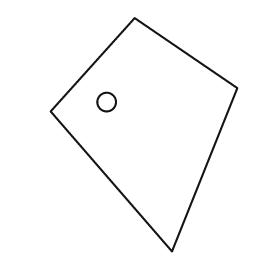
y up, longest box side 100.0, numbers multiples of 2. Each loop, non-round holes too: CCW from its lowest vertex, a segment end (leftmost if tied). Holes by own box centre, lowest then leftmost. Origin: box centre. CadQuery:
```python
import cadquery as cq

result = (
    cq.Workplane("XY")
    .moveTo(12.0, -50.0)
    .lineTo(40.0, 20.0)
    .lineTo(-4.0, 50.0)
    .lineTo(-40.0, 10.0)
    .close()
    .moveTo(-16.0, 14.0)
    .circle(4.0)
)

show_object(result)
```